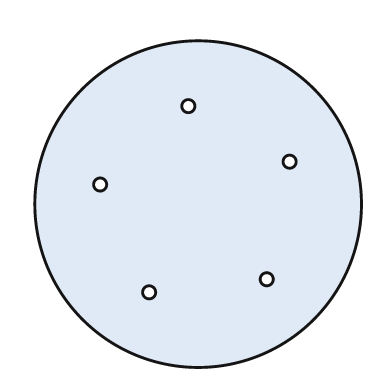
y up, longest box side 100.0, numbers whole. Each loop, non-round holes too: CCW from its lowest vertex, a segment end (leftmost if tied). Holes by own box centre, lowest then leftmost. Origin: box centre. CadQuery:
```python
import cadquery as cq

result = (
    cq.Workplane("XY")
    .moveTo(0.0, 0.0)
    .circle(50.0)
    .moveTo(-15.0, -27.0)
    .circle(2.0)
    .moveTo(21.0, -23.0)
    .circle(2.0)
    .moveTo(-30.0, 6.0)
    .circle(2.0)
    .moveTo(28.0, 13.0)
    .circle(2.0)
    .moveTo(-3.0, 30.0)
    .circle(2.0)
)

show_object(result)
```